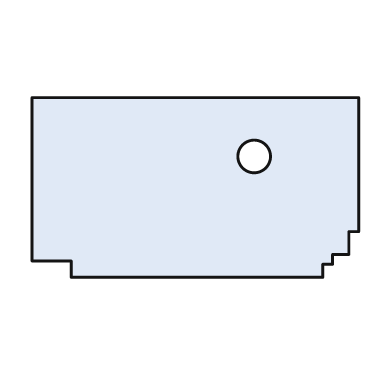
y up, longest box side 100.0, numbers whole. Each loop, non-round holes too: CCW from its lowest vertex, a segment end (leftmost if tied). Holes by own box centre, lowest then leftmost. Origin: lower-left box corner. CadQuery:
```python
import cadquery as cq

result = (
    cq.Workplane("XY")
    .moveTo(12.0, 0.0)
    .lineTo(89.0, 0.0)
    .lineTo(89.0, 4.0)
    .lineTo(92.0, 4.0)
    .lineTo(92.0, 7.0)
    .lineTo(97.0, 7.0)
    .lineTo(97.0, 14.0)
    .lineTo(100.0, 14.0)
    .lineTo(100.0, 55.0)
    .lineTo(0.0, 55.0)
    .lineTo(0.0, 5.0)
    .lineTo(12.0, 5.0)
    .close()
    .moveTo(68.0, 37.0)
    .circle(5.0)
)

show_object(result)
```